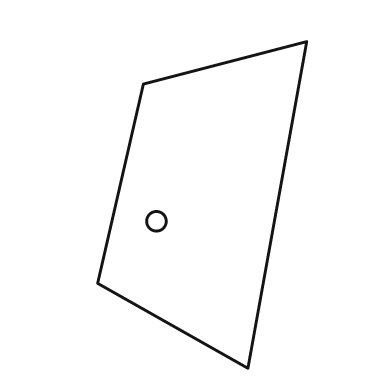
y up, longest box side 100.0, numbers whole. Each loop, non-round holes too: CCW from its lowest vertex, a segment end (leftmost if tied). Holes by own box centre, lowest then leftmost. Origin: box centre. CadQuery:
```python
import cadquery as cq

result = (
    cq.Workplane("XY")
    .moveTo(14.0, -50.0)
    .lineTo(32.0, 50.0)
    .lineTo(-18.0, 37.0)
    .lineTo(-32.0, -24.0)
    .close()
    .moveTo(-14.0, -5.0)
    .circle(3.0)
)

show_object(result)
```